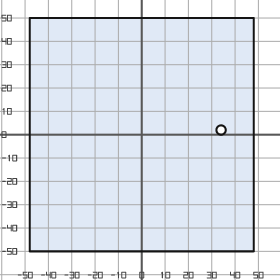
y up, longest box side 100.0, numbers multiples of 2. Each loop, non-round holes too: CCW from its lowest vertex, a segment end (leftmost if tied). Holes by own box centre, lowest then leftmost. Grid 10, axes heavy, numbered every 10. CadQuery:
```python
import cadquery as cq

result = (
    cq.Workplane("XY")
    .moveTo(-48.0, -50.0)
    .lineTo(48.0, -50.0)
    .lineTo(48.0, 50.0)
    .lineTo(-48.0, 50.0)
    .close()
    .moveTo(34.0, 2.0)
    .circle(2.0)
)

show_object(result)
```